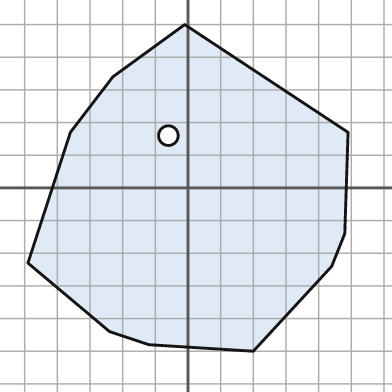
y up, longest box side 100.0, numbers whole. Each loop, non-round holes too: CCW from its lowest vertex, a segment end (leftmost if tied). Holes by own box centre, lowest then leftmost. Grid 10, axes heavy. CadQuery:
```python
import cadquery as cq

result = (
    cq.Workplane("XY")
    .moveTo(20.0, -50.0)
    .lineTo(44.0, -24.0)
    .lineTo(48.0, -14.0)
    .lineTo(49.0, 17.0)
    .lineTo(-1.0, 50.0)
    .lineTo(-23.0, 34.0)
    .lineTo(-36.0, 17.0)
    .lineTo(-49.0, -23.0)
    .lineTo(-24.0, -44.0)
    .lineTo(-12.0, -48.0)
    .close()
    .moveTo(-6.0, 16.0)
    .circle(3.0)
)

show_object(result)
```